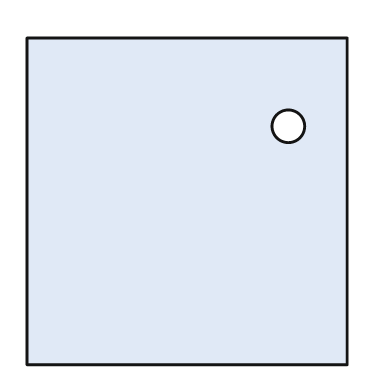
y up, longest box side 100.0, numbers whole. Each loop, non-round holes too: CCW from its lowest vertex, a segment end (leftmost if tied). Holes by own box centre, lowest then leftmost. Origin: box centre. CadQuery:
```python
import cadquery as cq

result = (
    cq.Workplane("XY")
    .moveTo(-49.0, -50.0)
    .lineTo(49.0, -50.0)
    .lineTo(49.0, 50.0)
    .lineTo(-49.0, 50.0)
    .close()
    .moveTo(31.0, 23.0)
    .circle(5.0)
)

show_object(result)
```